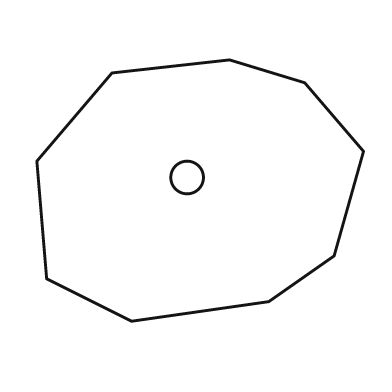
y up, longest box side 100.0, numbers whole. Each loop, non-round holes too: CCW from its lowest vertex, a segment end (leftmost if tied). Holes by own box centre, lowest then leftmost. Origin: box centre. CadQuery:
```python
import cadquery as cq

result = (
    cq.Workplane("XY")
    .moveTo(-21.0, -40.0)
    .lineTo(21.0, -34.0)
    .lineTo(41.0, -20.0)
    .lineTo(50.0, 12.0)
    .lineTo(32.0, 33.0)
    .lineTo(9.0, 40.0)
    .lineTo(-27.0, 36.0)
    .lineTo(-50.0, 9.0)
    .lineTo(-47.0, -27.0)
    .close()
    .moveTo(-4.0, 4.0)
    .circle(5.0)
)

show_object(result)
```